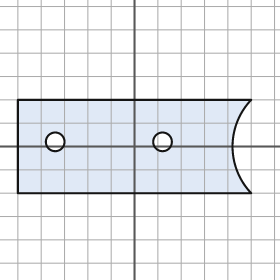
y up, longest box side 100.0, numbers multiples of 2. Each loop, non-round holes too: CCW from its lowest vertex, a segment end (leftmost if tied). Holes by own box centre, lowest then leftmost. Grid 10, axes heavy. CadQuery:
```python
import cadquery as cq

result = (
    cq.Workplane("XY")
    .moveTo(-50.0, -20.0)
    .lineTo(50.0, -20.0)
    .threePointArc((42.0, 0.0), (50.0, 20.0))
    .lineTo(-50.0, 20.0)
    .close()
    .moveTo(-34.0, 2.0)
    .circle(4.0)
    .moveTo(12.0, 2.0)
    .circle(4.0)
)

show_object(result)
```